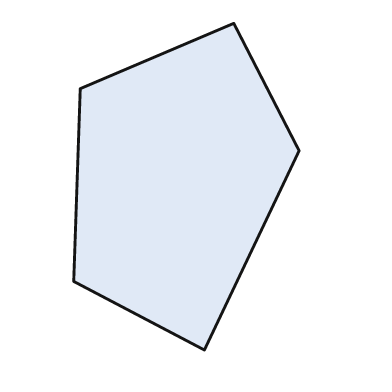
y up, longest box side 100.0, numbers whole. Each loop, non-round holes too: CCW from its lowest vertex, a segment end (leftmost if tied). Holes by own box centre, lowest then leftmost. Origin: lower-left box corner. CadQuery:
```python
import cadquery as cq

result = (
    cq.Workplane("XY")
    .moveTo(40.0, 0.0)
    .lineTo(69.0, 61.0)
    .lineTo(49.0, 100.0)
    .lineTo(2.0, 80.0)
    .lineTo(0.0, 21.0)
    .close()
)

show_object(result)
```